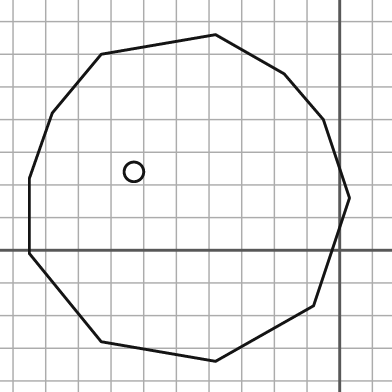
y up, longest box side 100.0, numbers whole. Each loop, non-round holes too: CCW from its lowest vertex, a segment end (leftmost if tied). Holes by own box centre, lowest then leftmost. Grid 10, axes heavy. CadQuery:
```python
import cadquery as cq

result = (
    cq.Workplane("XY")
    .moveTo(-38.0, -34.0)
    .lineTo(-8.0, -17.0)
    .lineTo(3.0, 16.0)
    .lineTo(-5.0, 40.0)
    .lineTo(-17.0, 54.0)
    .lineTo(-38.0, 66.0)
    .lineTo(-73.0, 60.0)
    .lineTo(-88.0, 42.0)
    .lineTo(-95.0, 22.0)
    .lineTo(-95.0, -1.0)
    .lineTo(-73.0, -28.0)
    .close()
    .moveTo(-63.0, 24.0)
    .circle(3.0)
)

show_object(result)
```